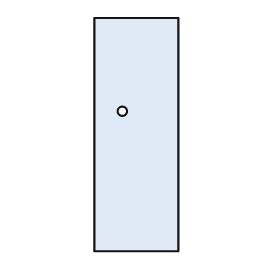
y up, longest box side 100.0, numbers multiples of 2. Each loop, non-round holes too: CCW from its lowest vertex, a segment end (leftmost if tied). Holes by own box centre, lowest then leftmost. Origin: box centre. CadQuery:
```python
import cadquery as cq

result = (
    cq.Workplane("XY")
    .moveTo(-18.0, -50.0)
    .lineTo(18.0, -50.0)
    .lineTo(18.0, 50.0)
    .lineTo(-18.0, 50.0)
    .close()
    .moveTo(-6.0, 10.0)
    .circle(2.0)
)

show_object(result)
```